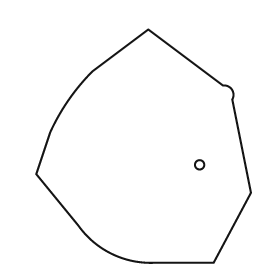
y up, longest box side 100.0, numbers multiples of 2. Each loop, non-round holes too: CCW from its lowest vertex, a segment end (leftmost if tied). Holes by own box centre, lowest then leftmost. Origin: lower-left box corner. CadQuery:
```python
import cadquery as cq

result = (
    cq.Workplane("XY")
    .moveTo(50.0, 0.0)
    .lineTo(76.0, 0.0)
    .lineTo(92.0, 30.0)
    .lineTo(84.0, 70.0)
    .threePointArc((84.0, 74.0), (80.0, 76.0))
    .lineTo(48.0, 100.0)
    .lineTo(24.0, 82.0)
    .threePointArc((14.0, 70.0), (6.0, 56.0))
    .lineTo(0.0, 38.0)
    .lineTo(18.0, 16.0)
    .threePointArc((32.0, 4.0), (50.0, 0.0))
    .close()
    .moveTo(70.0, 42.0)
    .circle(2.0)
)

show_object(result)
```